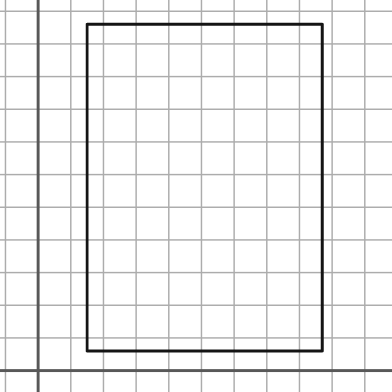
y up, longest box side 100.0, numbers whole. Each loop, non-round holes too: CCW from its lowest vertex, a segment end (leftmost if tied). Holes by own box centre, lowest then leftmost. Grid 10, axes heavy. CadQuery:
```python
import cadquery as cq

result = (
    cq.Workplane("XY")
    .moveTo(15.0, 6.0)
    .lineTo(87.0, 6.0)
    .lineTo(87.0, 106.0)
    .lineTo(15.0, 106.0)
    .close()
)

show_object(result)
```